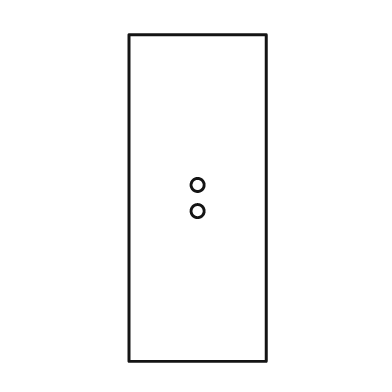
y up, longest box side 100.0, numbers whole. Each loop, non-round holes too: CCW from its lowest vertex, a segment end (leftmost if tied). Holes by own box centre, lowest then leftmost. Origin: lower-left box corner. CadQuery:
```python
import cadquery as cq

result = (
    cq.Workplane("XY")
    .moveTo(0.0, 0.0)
    .lineTo(42.0, 0.0)
    .lineTo(42.0, 100.0)
    .lineTo(0.0, 100.0)
    .close()
    .moveTo(21.0, 46.0)
    .circle(2.0)
    .moveTo(21.0, 54.0)
    .circle(2.0)
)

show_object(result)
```